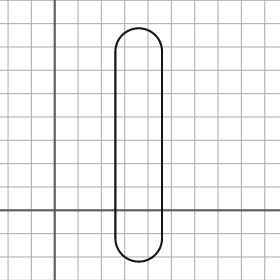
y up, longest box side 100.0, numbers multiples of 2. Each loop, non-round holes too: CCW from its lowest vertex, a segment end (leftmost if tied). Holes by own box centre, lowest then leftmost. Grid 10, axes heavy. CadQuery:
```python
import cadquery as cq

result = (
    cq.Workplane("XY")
    .moveTo(26.0, -12.0)
    .threePointArc((36.0, -22.0), (46.0, -12.0))
    .lineTo(46.0, 68.0)
    .threePointArc((36.0, 78.0), (26.0, 68.0))
    .close()
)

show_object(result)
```